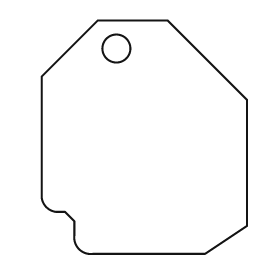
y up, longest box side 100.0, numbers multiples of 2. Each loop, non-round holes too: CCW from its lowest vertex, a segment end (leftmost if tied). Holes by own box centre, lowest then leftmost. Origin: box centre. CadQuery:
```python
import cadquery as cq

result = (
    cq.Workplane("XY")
    .moveTo(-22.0, -50.0)
    .lineTo(26.0, -50.0)
    .lineTo(44.0, -38.0)
    .lineTo(44.0, 16.0)
    .lineTo(10.0, 50.0)
    .lineTo(-20.0, 50.0)
    .lineTo(-44.0, 26.0)
    .lineTo(-44.0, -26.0)
    .threePointArc((-42.0, -30.0), (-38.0, -32.0))
    .lineTo(-34.0, -32.0)
    .lineTo(-30.0, -36.0)
    .lineTo(-30.0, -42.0)
    .threePointArc((-28.0, -48.0), (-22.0, -50.0))
    .close()
    .moveTo(-12.0, 38.0)
    .circle(6.0)
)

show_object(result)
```